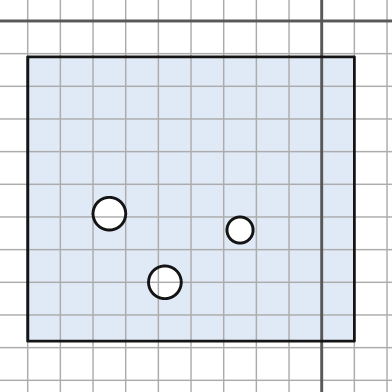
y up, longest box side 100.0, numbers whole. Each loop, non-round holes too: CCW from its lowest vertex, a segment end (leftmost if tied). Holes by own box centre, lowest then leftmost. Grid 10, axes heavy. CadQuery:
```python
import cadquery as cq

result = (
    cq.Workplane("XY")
    .moveTo(-90.0, -98.0)
    .lineTo(10.0, -98.0)
    .lineTo(10.0, -11.0)
    .lineTo(-90.0, -11.0)
    .close()
    .moveTo(-48.0, -80.0)
    .circle(5.0)
    .moveTo(-25.0, -64.0)
    .circle(4.0)
    .moveTo(-65.0, -59.0)
    .circle(5.0)
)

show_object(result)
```